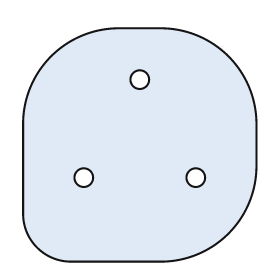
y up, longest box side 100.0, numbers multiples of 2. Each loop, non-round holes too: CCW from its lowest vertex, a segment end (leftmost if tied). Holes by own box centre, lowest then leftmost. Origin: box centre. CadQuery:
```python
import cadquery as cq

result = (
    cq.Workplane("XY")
    .moveTo(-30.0, -50.0)
    .lineTo(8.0, -50.0)
    .threePointArc((38.0, -38.0), (50.0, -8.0))
    .lineTo(50.0, 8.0)
    .threePointArc((38.0, 38.0), (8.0, 50.0))
    .lineTo(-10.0, 50.0)
    .threePointArc((-38.0, 38.0), (-50.0, 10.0))
    .lineTo(-50.0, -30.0)
    .threePointArc((-44.0, -44.0), (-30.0, -50.0))
    .close()
    .moveTo(-24.0, -14.0)
    .circle(4.0)
    .moveTo(24.0, -14.0)
    .circle(4.0)
    .moveTo(0.0, 28.0)
    .circle(4.0)
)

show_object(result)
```